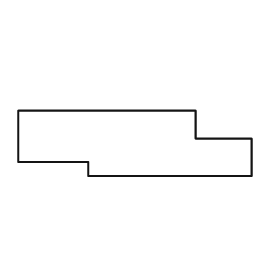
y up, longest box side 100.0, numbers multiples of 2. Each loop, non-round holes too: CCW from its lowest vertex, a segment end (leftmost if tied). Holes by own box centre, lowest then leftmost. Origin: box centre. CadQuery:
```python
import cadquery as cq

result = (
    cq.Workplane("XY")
    .moveTo(-20.0, -14.0)
    .lineTo(50.0, -14.0)
    .lineTo(50.0, 2.0)
    .lineTo(26.0, 2.0)
    .lineTo(26.0, 14.0)
    .lineTo(-50.0, 14.0)
    .lineTo(-50.0, -8.0)
    .lineTo(-20.0, -8.0)
    .close()
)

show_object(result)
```